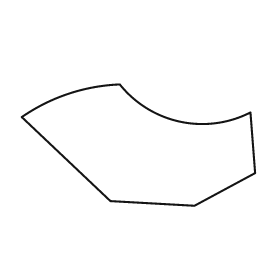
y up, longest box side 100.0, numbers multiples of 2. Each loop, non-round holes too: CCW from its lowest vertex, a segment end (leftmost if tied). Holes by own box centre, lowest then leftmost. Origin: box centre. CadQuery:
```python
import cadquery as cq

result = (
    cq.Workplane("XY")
    .moveTo(24.0, -26.0)
    .lineTo(50.0, -12.0)
    .lineTo(48.0, 14.0)
    .threePointArc((18.0, 10.0), (-8.0, 26.0))
    .threePointArc((-30.0, 22.0), (-50.0, 12.0))
    .lineTo(-12.0, -24.0)
    .close()
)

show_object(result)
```